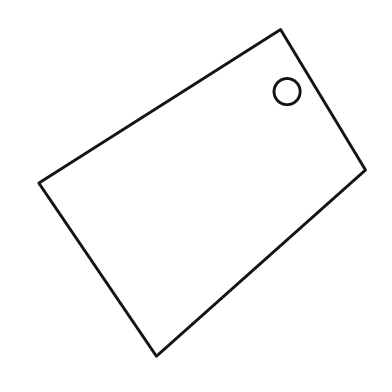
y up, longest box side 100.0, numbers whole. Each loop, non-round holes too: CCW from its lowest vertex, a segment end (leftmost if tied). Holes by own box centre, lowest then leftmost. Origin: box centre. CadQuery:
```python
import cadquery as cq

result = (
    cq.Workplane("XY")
    .moveTo(-14.0, -50.0)
    .lineTo(50.0, 7.0)
    .lineTo(24.0, 50.0)
    .lineTo(-50.0, 3.0)
    .close()
    .moveTo(26.0, 31.0)
    .circle(4.0)
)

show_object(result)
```